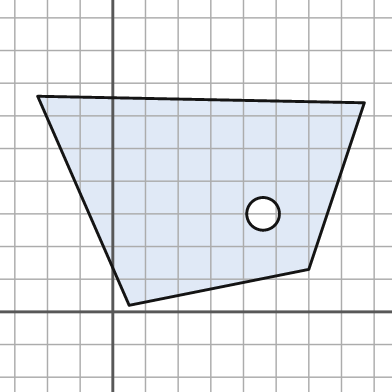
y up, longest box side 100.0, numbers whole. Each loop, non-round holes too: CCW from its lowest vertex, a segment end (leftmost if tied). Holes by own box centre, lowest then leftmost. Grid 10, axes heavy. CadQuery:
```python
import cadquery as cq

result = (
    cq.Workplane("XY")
    .moveTo(5.0, 2.0)
    .lineTo(60.0, 13.0)
    .lineTo(77.0, 64.0)
    .lineTo(-23.0, 66.0)
    .close()
    .moveTo(46.0, 30.0)
    .circle(5.0)
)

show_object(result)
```